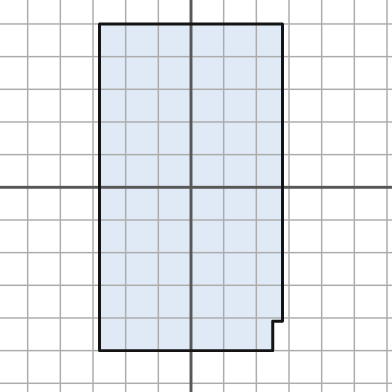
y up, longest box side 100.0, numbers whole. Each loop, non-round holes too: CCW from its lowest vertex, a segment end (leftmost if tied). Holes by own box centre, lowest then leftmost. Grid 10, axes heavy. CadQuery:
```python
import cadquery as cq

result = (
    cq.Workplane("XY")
    .moveTo(-28.0, -50.0)
    .lineTo(25.0, -50.0)
    .lineTo(25.0, -41.0)
    .lineTo(28.0, -41.0)
    .lineTo(28.0, 50.0)
    .lineTo(-28.0, 50.0)
    .close()
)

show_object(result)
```